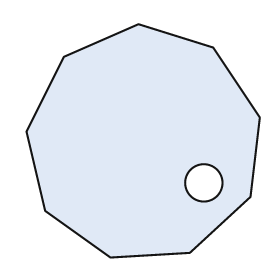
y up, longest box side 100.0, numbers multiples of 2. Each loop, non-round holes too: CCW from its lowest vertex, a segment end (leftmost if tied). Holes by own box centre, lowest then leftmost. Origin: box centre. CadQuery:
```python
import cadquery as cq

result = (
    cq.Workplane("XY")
    .moveTo(-14.0, -50.0)
    .lineTo(20.0, -48.0)
    .lineTo(46.0, -24.0)
    .lineTo(50.0, 10.0)
    .lineTo(30.0, 40.0)
    .lineTo(-2.0, 50.0)
    .lineTo(-34.0, 36.0)
    .lineTo(-50.0, 4.0)
    .lineTo(-42.0, -30.0)
    .close()
    .moveTo(26.0, -18.0)
    .circle(8.0)
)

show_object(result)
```